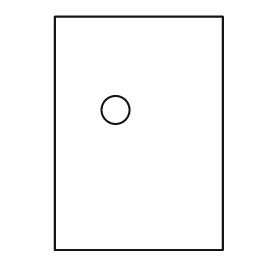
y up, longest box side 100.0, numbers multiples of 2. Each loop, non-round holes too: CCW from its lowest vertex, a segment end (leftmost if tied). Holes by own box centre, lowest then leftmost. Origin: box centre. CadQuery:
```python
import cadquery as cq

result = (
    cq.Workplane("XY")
    .moveTo(-36.0, -50.0)
    .lineTo(36.0, -50.0)
    .lineTo(36.0, 50.0)
    .lineTo(-36.0, 50.0)
    .close()
    .moveTo(-10.0, 10.0)
    .circle(6.0)
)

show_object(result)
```